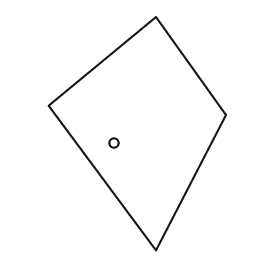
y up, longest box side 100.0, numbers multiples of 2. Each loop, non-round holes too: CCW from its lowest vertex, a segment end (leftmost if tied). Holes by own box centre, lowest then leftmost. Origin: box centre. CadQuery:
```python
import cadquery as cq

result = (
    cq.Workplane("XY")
    .moveTo(8.0, -50.0)
    .lineTo(38.0, 8.0)
    .lineTo(8.0, 50.0)
    .lineTo(-38.0, 12.0)
    .close()
    .moveTo(-10.0, -4.0)
    .circle(2.0)
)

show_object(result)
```